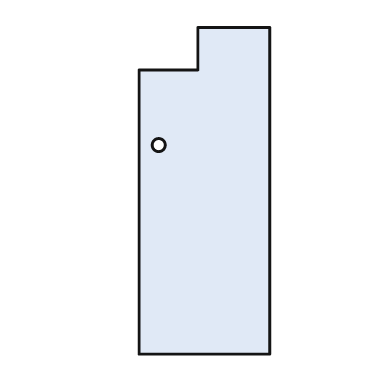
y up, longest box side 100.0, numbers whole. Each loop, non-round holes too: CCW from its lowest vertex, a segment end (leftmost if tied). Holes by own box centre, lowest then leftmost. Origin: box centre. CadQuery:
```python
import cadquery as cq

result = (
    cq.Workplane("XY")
    .moveTo(-20.0, -50.0)
    .lineTo(20.0, -50.0)
    .lineTo(20.0, 50.0)
    .lineTo(-2.0, 50.0)
    .lineTo(-2.0, 37.0)
    .lineTo(-20.0, 37.0)
    .close()
    .moveTo(-14.0, 14.0)
    .circle(2.0)
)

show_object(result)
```